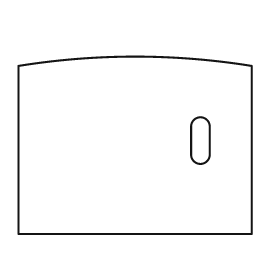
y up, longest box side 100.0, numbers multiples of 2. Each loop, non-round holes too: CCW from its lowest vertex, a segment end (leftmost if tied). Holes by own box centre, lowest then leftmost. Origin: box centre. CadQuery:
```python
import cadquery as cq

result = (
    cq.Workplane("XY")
    .moveTo(-50.0, -38.0)
    .lineTo(50.0, -38.0)
    .lineTo(50.0, 34.0)
    .threePointArc((0.0, 38.0), (-50.0, 34.0))
    .close()
    .moveTo(24.0, -4.0)
    .threePointArc((28.0, -8.0), (32.0, -4.0))
    .lineTo(32.0, 8.0)
    .threePointArc((28.0, 12.0), (24.0, 8.0))
    .close()
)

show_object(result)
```